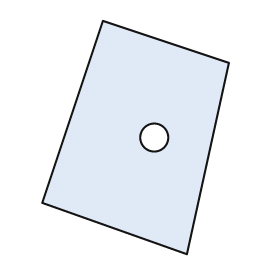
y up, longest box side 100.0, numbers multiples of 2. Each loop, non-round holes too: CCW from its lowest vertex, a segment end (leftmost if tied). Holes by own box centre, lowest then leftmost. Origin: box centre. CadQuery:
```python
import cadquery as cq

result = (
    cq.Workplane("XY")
    .moveTo(22.0, -50.0)
    .lineTo(40.0, 32.0)
    .lineTo(-14.0, 50.0)
    .lineTo(-40.0, -28.0)
    .close()
    .moveTo(8.0, 0.0)
    .circle(6.0)
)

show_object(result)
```